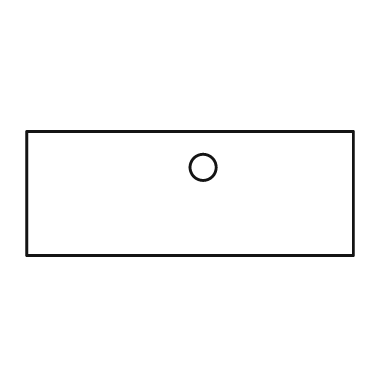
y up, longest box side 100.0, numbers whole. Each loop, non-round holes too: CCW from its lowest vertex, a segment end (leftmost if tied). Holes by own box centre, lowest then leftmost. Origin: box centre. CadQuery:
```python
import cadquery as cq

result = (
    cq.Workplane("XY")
    .moveTo(-50.0, -19.0)
    .lineTo(50.0, -19.0)
    .lineTo(50.0, 19.0)
    .lineTo(-50.0, 19.0)
    .close()
    .moveTo(4.0, 8.0)
    .circle(4.0)
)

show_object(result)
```